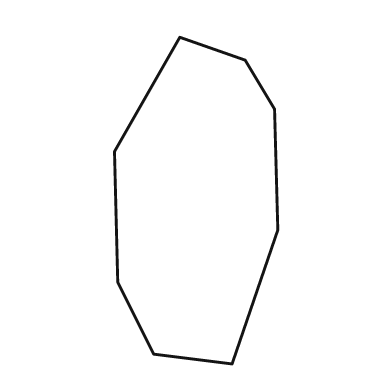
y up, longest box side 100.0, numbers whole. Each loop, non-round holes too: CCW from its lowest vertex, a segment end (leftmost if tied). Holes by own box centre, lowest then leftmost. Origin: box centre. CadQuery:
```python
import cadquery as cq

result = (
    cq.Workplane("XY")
    .moveTo(11.0, -50.0)
    .lineTo(25.0, -9.0)
    .lineTo(24.0, 28.0)
    .lineTo(15.0, 43.0)
    .lineTo(-5.0, 50.0)
    .lineTo(-25.0, 15.0)
    .lineTo(-24.0, -25.0)
    .lineTo(-13.0, -47.0)
    .close()
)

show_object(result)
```